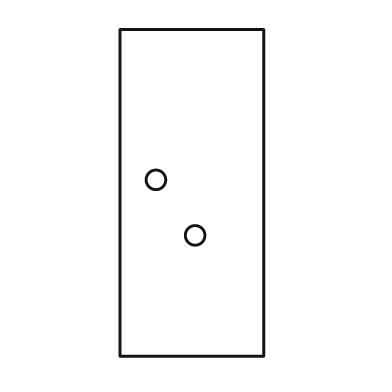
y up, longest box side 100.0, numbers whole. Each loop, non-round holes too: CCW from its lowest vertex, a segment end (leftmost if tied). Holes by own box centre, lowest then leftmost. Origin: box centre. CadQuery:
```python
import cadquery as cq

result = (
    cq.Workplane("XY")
    .moveTo(-22.0, -50.0)
    .lineTo(22.0, -50.0)
    .lineTo(22.0, 50.0)
    .lineTo(-22.0, 50.0)
    .close()
    .moveTo(1.0, -13.0)
    .circle(3.0)
    .moveTo(-11.0, 4.0)
    .circle(3.0)
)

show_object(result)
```